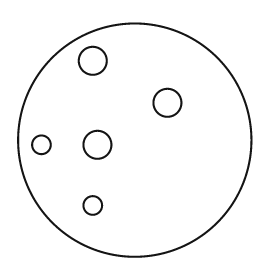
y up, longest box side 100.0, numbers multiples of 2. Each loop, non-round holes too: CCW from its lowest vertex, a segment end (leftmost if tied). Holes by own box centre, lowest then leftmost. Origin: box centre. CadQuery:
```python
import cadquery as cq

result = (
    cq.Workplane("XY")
    .moveTo(0.0, 0.0)
    .circle(50.0)
    .moveTo(-18.0, -28.0)
    .circle(4.0)
    .moveTo(-40.0, -2.0)
    .circle(4.0)
    .moveTo(-16.0, -2.0)
    .circle(6.0)
    .moveTo(14.0, 16.0)
    .circle(6.0)
    .moveTo(-18.0, 34.0)
    .circle(6.0)
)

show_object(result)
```